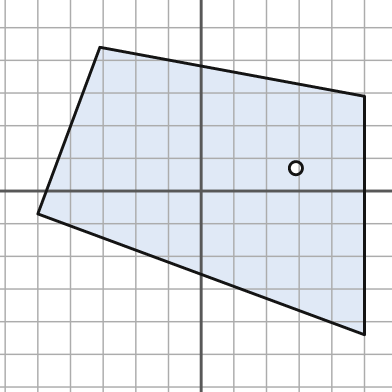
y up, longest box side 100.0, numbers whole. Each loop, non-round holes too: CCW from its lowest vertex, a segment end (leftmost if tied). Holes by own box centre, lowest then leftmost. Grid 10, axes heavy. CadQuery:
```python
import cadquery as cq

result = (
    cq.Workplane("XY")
    .moveTo(50.0, -44.0)
    .lineTo(50.0, 29.0)
    .lineTo(-31.0, 44.0)
    .lineTo(-50.0, -7.0)
    .close()
    .moveTo(29.0, 7.0)
    .circle(2.0)
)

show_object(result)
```